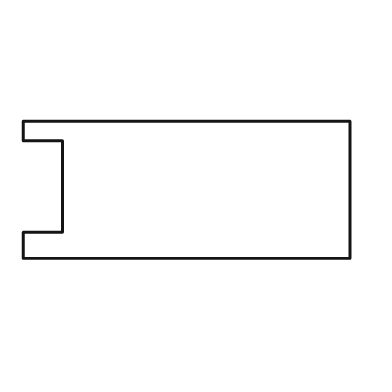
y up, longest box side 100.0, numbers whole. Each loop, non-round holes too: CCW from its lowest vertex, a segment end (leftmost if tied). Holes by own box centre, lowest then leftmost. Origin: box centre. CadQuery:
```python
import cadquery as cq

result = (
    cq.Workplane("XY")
    .moveTo(-50.0, -21.0)
    .lineTo(50.0, -21.0)
    .lineTo(50.0, 21.0)
    .lineTo(-50.0, 21.0)
    .lineTo(-50.0, 15.0)
    .lineTo(-38.0, 15.0)
    .lineTo(-38.0, -13.0)
    .lineTo(-50.0, -13.0)
    .close()
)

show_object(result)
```